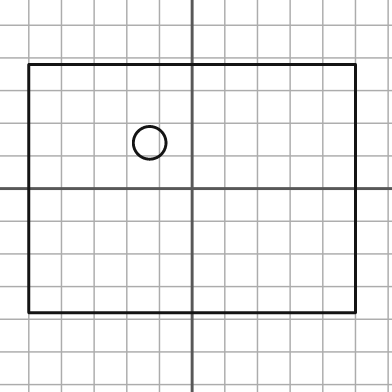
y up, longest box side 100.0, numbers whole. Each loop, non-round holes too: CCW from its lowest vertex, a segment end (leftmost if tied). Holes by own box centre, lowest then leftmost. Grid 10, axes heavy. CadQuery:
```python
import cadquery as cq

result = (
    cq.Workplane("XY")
    .moveTo(-50.0, -38.0)
    .lineTo(50.0, -38.0)
    .lineTo(50.0, 38.0)
    .lineTo(-50.0, 38.0)
    .close()
    .moveTo(-13.0, 14.0)
    .circle(5.0)
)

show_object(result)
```